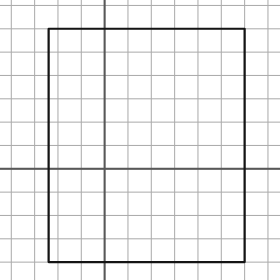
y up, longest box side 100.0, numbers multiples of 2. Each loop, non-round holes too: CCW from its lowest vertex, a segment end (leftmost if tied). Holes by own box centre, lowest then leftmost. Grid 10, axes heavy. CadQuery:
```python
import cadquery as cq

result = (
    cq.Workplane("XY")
    .moveTo(-24.0, -40.0)
    .lineTo(60.0, -40.0)
    .lineTo(60.0, 60.0)
    .lineTo(-24.0, 60.0)
    .close()
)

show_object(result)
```